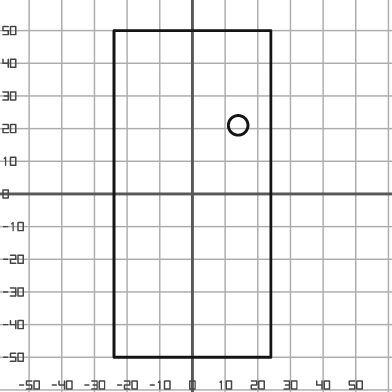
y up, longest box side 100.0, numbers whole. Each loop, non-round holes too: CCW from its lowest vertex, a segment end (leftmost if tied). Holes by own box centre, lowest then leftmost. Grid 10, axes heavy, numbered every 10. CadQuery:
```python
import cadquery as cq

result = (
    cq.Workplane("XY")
    .moveTo(-24.0, -50.0)
    .lineTo(24.0, -50.0)
    .lineTo(24.0, 50.0)
    .lineTo(-24.0, 50.0)
    .close()
    .moveTo(14.0, 21.0)
    .circle(3.0)
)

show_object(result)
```